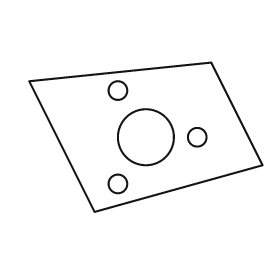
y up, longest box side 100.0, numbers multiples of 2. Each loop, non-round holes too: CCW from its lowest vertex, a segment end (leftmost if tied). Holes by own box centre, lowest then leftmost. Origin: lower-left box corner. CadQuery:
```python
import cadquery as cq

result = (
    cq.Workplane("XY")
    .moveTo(28.0, 0.0)
    .lineTo(100.0, 20.0)
    .lineTo(78.0, 64.0)
    .lineTo(0.0, 56.0)
    .close()
    .moveTo(38.0, 12.0)
    .circle(4.0)
    .moveTo(50.0, 32.0)
    .circle(12.0)
    .moveTo(72.0, 32.0)
    .circle(4.0)
    .moveTo(38.0, 52.0)
    .circle(4.0)
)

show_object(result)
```